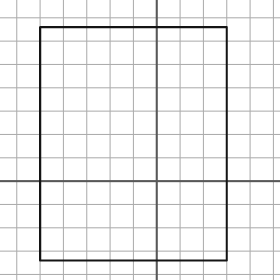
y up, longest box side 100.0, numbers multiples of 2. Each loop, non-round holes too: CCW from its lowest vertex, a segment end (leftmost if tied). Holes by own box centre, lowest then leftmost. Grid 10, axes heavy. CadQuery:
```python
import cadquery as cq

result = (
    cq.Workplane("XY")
    .moveTo(-50.0, -34.0)
    .lineTo(30.0, -34.0)
    .lineTo(30.0, 66.0)
    .lineTo(-50.0, 66.0)
    .close()
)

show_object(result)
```